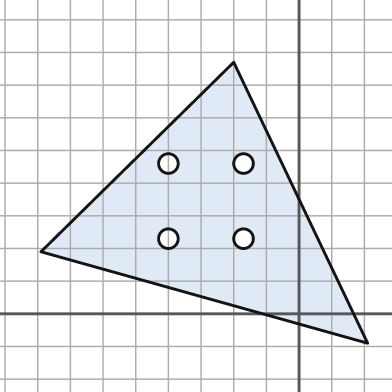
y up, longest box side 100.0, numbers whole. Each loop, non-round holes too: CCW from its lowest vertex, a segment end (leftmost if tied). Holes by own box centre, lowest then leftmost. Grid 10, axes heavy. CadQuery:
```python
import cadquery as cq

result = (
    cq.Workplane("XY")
    .moveTo(21.0, -9.0)
    .lineTo(-20.0, 77.0)
    .lineTo(-79.0, 19.0)
    .close()
    .moveTo(-40.0, 23.0)
    .circle(3.0)
    .moveTo(-17.0, 23.0)
    .circle(3.0)
    .moveTo(-40.0, 46.0)
    .circle(3.0)
    .moveTo(-17.0, 46.0)
    .circle(3.0)
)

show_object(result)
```